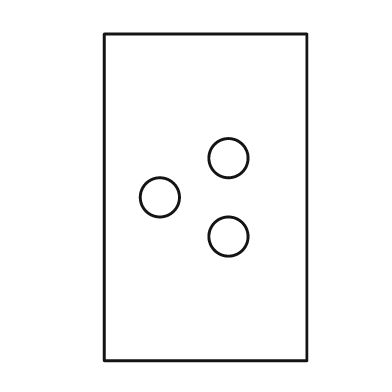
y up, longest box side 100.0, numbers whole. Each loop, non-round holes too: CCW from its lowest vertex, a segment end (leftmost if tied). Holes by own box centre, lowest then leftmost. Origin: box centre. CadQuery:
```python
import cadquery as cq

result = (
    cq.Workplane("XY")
    .moveTo(-31.0, -50.0)
    .lineTo(31.0, -50.0)
    .lineTo(31.0, 50.0)
    .lineTo(-31.0, 50.0)
    .close()
    .moveTo(7.0, -12.0)
    .circle(6.0)
    .moveTo(-14.0, 0.0)
    .circle(6.0)
    .moveTo(7.0, 12.0)
    .circle(6.0)
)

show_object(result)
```